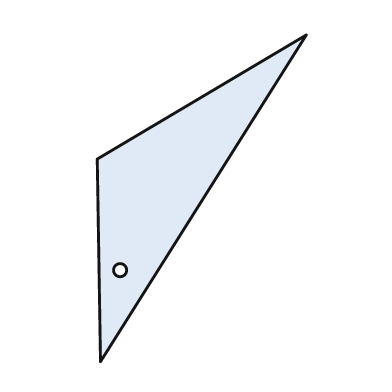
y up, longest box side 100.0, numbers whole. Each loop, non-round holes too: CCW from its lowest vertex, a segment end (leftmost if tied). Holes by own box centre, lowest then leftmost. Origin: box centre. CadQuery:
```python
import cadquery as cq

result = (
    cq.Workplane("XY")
    .moveTo(-31.0, -50.0)
    .lineTo(32.0, 50.0)
    .lineTo(-32.0, 12.0)
    .close()
    .moveTo(-25.0, -22.0)
    .circle(2.0)
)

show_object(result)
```